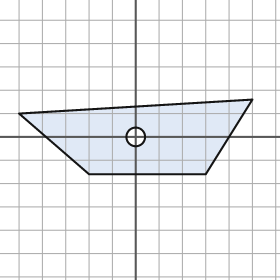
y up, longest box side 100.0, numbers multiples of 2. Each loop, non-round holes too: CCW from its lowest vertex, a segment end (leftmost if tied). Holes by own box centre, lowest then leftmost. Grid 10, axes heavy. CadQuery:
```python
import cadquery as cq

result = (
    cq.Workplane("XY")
    .moveTo(-20.0, -16.0)
    .lineTo(30.0, -16.0)
    .lineTo(50.0, 16.0)
    .lineTo(-50.0, 10.0)
    .close()
    .moveTo(0.0, 0.0)
    .circle(4.0)
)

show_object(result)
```